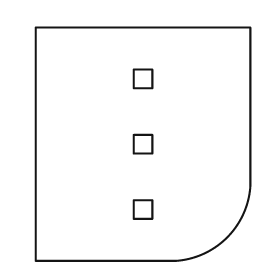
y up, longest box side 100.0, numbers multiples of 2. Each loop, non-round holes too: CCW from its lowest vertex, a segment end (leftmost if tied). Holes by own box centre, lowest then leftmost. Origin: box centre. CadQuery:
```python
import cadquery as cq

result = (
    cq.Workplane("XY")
    .moveTo(-46.0, -50.0)
    .lineTo(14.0, -50.0)
    .threePointArc((36.0, -40.0), (46.0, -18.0))
    .lineTo(46.0, 50.0)
    .lineTo(-46.0, 50.0)
    .close()
    .moveTo(-4.0, -32.0)
    .lineTo(4.0, -32.0)
    .lineTo(4.0, -24.0)
    .lineTo(-4.0, -24.0)
    .close()
    .moveTo(-4.0, -4.0)
    .lineTo(4.0, -4.0)
    .lineTo(4.0, 4.0)
    .lineTo(-4.0, 4.0)
    .close()
    .moveTo(-4.0, 24.0)
    .lineTo(4.0, 24.0)
    .lineTo(4.0, 32.0)
    .lineTo(-4.0, 32.0)
    .close()
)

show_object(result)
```